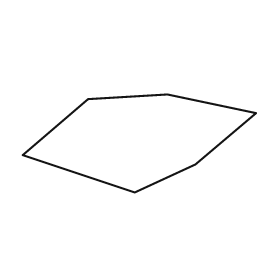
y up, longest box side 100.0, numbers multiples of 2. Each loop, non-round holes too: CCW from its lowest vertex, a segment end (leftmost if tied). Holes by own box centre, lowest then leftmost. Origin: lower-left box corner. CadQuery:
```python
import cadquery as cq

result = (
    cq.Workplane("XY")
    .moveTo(48.0, 0.0)
    .lineTo(74.0, 12.0)
    .lineTo(100.0, 34.0)
    .lineTo(62.0, 42.0)
    .lineTo(28.0, 40.0)
    .lineTo(0.0, 16.0)
    .close()
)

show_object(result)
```